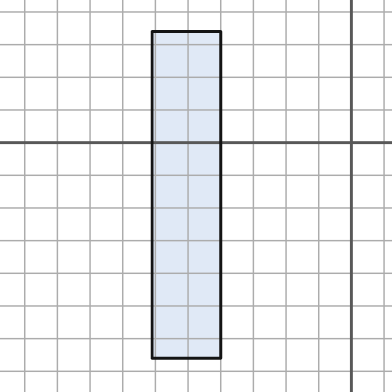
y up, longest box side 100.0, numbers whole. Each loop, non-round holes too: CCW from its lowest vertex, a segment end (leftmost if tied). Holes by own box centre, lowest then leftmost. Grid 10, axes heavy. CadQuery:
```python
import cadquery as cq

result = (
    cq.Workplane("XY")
    .moveTo(-61.0, -66.0)
    .lineTo(-40.0, -66.0)
    .lineTo(-40.0, 34.0)
    .lineTo(-61.0, 34.0)
    .close()
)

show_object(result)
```